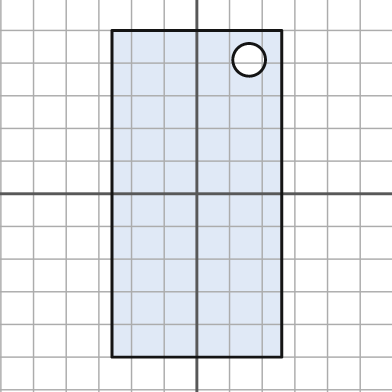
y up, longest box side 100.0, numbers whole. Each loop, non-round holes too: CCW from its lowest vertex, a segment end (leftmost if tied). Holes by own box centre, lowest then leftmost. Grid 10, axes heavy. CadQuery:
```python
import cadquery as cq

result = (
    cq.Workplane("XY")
    .moveTo(-26.0, -50.0)
    .lineTo(26.0, -50.0)
    .lineTo(26.0, 50.0)
    .lineTo(-26.0, 50.0)
    .close()
    .moveTo(16.0, 41.0)
    .circle(5.0)
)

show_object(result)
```